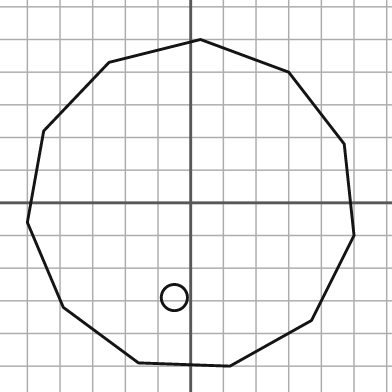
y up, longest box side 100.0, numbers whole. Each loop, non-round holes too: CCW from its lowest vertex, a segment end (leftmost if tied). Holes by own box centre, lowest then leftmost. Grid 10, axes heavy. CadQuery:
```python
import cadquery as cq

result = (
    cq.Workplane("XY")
    .moveTo(12.0, -50.0)
    .lineTo(37.0, -36.0)
    .lineTo(50.0, -10.0)
    .lineTo(47.0, 18.0)
    .lineTo(30.0, 40.0)
    .lineTo(3.0, 50.0)
    .lineTo(-25.0, 43.0)
    .lineTo(-45.0, 22.0)
    .lineTo(-50.0, -6.0)
    .lineTo(-39.0, -32.0)
    .lineTo(-16.0, -49.0)
    .close()
    .moveTo(-5.0, -29.0)
    .circle(4.0)
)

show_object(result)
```